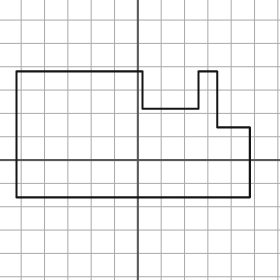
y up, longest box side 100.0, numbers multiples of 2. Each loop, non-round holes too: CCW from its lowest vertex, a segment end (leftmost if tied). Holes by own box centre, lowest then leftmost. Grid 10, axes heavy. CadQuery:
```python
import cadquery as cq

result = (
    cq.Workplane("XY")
    .moveTo(-52.0, -16.0)
    .lineTo(48.0, -16.0)
    .lineTo(48.0, 14.0)
    .lineTo(34.0, 14.0)
    .lineTo(34.0, 38.0)
    .lineTo(26.0, 38.0)
    .lineTo(26.0, 22.0)
    .lineTo(2.0, 22.0)
    .lineTo(2.0, 38.0)
    .lineTo(-52.0, 38.0)
    .close()
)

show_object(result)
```